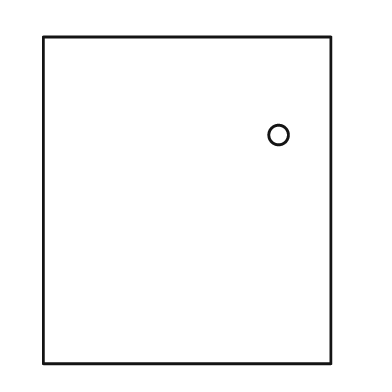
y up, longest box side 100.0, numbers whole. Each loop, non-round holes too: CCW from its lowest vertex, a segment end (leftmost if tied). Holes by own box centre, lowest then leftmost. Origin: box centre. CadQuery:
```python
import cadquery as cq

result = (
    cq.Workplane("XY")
    .moveTo(-44.0, -50.0)
    .lineTo(44.0, -50.0)
    .lineTo(44.0, 50.0)
    .lineTo(-44.0, 50.0)
    .close()
    .moveTo(28.0, 20.0)
    .circle(3.0)
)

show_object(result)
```